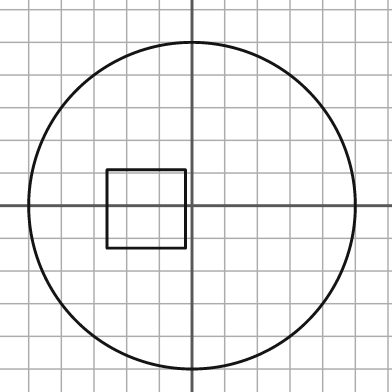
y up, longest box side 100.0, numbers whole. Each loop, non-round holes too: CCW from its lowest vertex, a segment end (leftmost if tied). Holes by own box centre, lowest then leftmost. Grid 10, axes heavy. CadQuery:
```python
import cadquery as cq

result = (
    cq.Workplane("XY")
    .moveTo(0.0, 0.0)
    .circle(50.0)
    .moveTo(-26.0, -13.0)
    .lineTo(-2.0, -13.0)
    .lineTo(-2.0, 11.0)
    .lineTo(-26.0, 11.0)
    .close()
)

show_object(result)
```